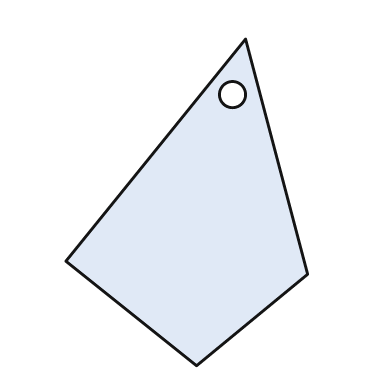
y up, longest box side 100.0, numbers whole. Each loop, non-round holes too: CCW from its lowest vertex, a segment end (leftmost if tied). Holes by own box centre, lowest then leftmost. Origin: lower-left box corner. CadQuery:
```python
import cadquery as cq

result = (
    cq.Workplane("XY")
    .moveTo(40.0, 0.0)
    .lineTo(74.0, 28.0)
    .lineTo(55.0, 100.0)
    .lineTo(0.0, 32.0)
    .close()
    .moveTo(51.0, 83.0)
    .circle(4.0)
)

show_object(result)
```